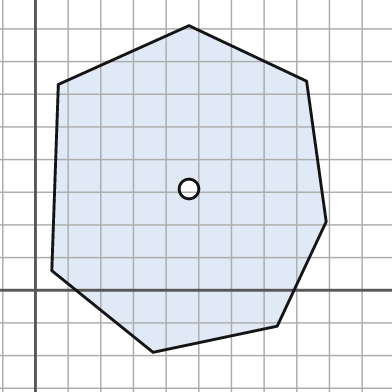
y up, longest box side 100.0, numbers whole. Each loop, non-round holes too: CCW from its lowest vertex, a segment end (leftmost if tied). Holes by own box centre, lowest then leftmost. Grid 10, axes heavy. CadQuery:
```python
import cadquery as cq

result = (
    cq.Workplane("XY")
    .moveTo(36.0, -19.0)
    .lineTo(74.0, -11.0)
    .lineTo(89.0, 21.0)
    .lineTo(83.0, 64.0)
    .lineTo(47.0, 81.0)
    .lineTo(7.0, 63.0)
    .lineTo(5.0, 6.0)
    .close()
    .moveTo(47.0, 31.0)
    .circle(3.0)
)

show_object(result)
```